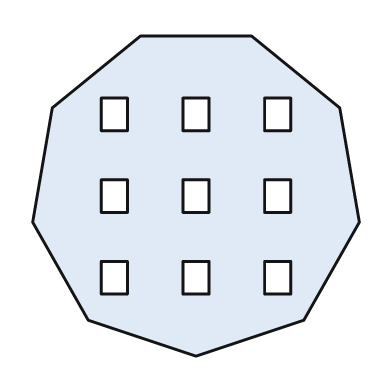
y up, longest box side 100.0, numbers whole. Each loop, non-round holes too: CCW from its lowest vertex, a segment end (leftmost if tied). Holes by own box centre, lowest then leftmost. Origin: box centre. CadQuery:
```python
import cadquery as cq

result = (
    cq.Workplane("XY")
    .moveTo(0.0, -49.0)
    .lineTo(33.0, -38.0)
    .lineTo(50.0, -8.0)
    .lineTo(44.0, 27.0)
    .lineTo(17.0, 49.0)
    .lineTo(-17.0, 49.0)
    .lineTo(-44.0, 27.0)
    .lineTo(-50.0, -8.0)
    .lineTo(-33.0, -38.0)
    .close()
    .moveTo(-29.0, -30.0)
    .lineTo(-21.0, -30.0)
    .lineTo(-21.0, -20.0)
    .lineTo(-29.0, -20.0)
    .close()
    .moveTo(-4.0, -30.0)
    .lineTo(4.0, -30.0)
    .lineTo(4.0, -20.0)
    .lineTo(-4.0, -20.0)
    .close()
    .moveTo(21.0, -30.0)
    .lineTo(29.0, -30.0)
    .lineTo(29.0, -20.0)
    .lineTo(21.0, -20.0)
    .close()
    .moveTo(-29.0, -5.0)
    .lineTo(-21.0, -5.0)
    .lineTo(-21.0, 5.0)
    .lineTo(-29.0, 5.0)
    .close()
    .moveTo(-4.0, -5.0)
    .lineTo(4.0, -5.0)
    .lineTo(4.0, 5.0)
    .lineTo(-4.0, 5.0)
    .close()
    .moveTo(21.0, -5.0)
    .lineTo(29.0, -5.0)
    .lineTo(29.0, 5.0)
    .lineTo(21.0, 5.0)
    .close()
    .moveTo(-29.0, 20.0)
    .lineTo(-21.0, 20.0)
    .lineTo(-21.0, 30.0)
    .lineTo(-29.0, 30.0)
    .close()
    .moveTo(-4.0, 20.0)
    .lineTo(4.0, 20.0)
    .lineTo(4.0, 30.0)
    .lineTo(-4.0, 30.0)
    .close()
    .moveTo(21.0, 20.0)
    .lineTo(29.0, 20.0)
    .lineTo(29.0, 30.0)
    .lineTo(21.0, 30.0)
    .close()
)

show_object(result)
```